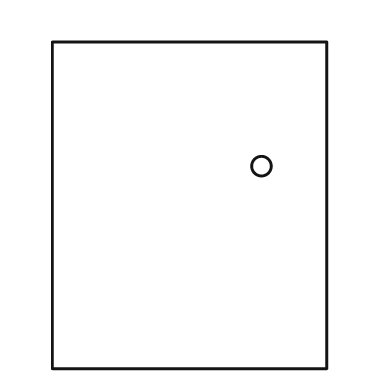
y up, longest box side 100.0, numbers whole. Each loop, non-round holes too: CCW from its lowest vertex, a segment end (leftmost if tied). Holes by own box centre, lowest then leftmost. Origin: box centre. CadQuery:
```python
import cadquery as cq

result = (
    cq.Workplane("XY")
    .moveTo(-42.0, -50.0)
    .lineTo(42.0, -50.0)
    .lineTo(42.0, 50.0)
    .lineTo(-42.0, 50.0)
    .close()
    .moveTo(22.0, 12.0)
    .circle(3.0)
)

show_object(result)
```